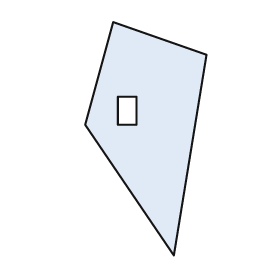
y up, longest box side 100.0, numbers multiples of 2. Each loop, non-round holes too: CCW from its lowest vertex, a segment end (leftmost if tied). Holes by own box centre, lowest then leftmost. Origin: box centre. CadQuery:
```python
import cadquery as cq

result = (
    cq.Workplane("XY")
    .moveTo(12.0, -50.0)
    .lineTo(26.0, 36.0)
    .lineTo(-14.0, 50.0)
    .lineTo(-26.0, 6.0)
    .close()
    .moveTo(-12.0, 6.0)
    .lineTo(-4.0, 6.0)
    .lineTo(-4.0, 18.0)
    .lineTo(-12.0, 18.0)
    .close()
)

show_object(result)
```